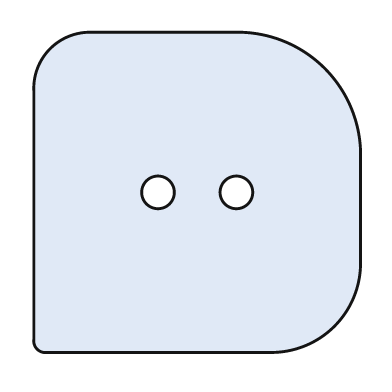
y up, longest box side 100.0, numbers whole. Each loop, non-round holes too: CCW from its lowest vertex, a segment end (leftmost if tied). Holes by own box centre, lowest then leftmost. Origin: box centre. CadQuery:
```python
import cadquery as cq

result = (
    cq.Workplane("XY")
    .moveTo(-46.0, -49.0)
    .lineTo(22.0, -49.0)
    .threePointArc((42.0, -41.0), (50.0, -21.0))
    .lineTo(50.0, 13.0)
    .threePointArc((39.0, 38.0), (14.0, 49.0))
    .lineTo(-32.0, 49.0)
    .threePointArc((-45.0, 44.0), (-50.0, 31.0))
    .lineTo(-50.0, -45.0)
    .threePointArc((-49.0, -48.0), (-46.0, -49.0))
    .close()
    .moveTo(-12.0, 0.0)
    .circle(5.0)
    .moveTo(12.0, 0.0)
    .circle(5.0)
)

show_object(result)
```